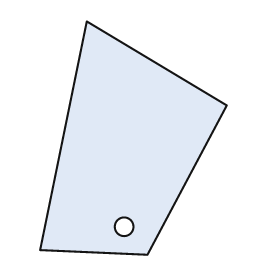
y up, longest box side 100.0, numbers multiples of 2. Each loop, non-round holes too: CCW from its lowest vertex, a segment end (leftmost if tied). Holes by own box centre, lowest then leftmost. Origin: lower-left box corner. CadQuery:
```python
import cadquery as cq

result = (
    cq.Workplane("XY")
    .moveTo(46.0, 0.0)
    .lineTo(80.0, 64.0)
    .lineTo(20.0, 100.0)
    .lineTo(0.0, 2.0)
    .close()
    .moveTo(36.0, 12.0)
    .circle(4.0)
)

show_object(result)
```